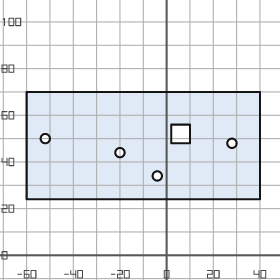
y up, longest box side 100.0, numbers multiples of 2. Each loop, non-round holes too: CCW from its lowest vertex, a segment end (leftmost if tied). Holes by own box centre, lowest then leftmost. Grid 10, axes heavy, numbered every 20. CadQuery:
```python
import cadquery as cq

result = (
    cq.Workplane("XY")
    .moveTo(-60.0, 24.0)
    .lineTo(40.0, 24.0)
    .lineTo(40.0, 70.0)
    .lineTo(-60.0, 70.0)
    .close()
    .moveTo(-4.0, 34.0)
    .circle(2.0)
    .moveTo(-20.0, 44.0)
    .circle(2.0)
    .moveTo(28.0, 48.0)
    .circle(2.0)
    .moveTo(-52.0, 50.0)
    .circle(2.0)
    .moveTo(2.0, 48.0)
    .lineTo(10.0, 48.0)
    .lineTo(10.0, 56.0)
    .lineTo(2.0, 56.0)
    .close()
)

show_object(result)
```